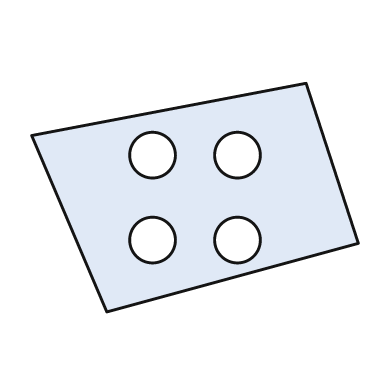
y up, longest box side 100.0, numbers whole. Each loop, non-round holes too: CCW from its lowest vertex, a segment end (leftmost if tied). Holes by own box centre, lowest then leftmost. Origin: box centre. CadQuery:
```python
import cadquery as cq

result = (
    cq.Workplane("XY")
    .moveTo(-27.0, -35.0)
    .lineTo(50.0, -14.0)
    .lineTo(34.0, 35.0)
    .lineTo(-50.0, 19.0)
    .close()
    .moveTo(-13.0, -13.0)
    .circle(7.0)
    .moveTo(13.0, -13.0)
    .circle(7.0)
    .moveTo(-13.0, 13.0)
    .circle(7.0)
    .moveTo(13.0, 13.0)
    .circle(7.0)
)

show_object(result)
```